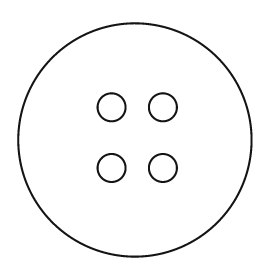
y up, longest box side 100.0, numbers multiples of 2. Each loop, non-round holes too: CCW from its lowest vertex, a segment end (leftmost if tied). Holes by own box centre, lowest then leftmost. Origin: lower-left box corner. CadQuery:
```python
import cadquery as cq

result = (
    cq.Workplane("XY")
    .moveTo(50.0, 50.0)
    .circle(50.0)
    .moveTo(40.0, 38.0)
    .circle(6.0)
    .moveTo(62.0, 38.0)
    .circle(6.0)
    .moveTo(40.0, 64.0)
    .circle(6.0)
    .moveTo(62.0, 64.0)
    .circle(6.0)
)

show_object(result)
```